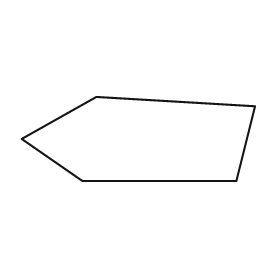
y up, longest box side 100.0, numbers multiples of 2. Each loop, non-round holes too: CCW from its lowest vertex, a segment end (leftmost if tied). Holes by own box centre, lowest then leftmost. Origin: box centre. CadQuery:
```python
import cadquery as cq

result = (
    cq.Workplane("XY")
    .moveTo(-24.0, -18.0)
    .lineTo(42.0, -18.0)
    .lineTo(50.0, 14.0)
    .lineTo(-18.0, 18.0)
    .lineTo(-50.0, 0.0)
    .close()
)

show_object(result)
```